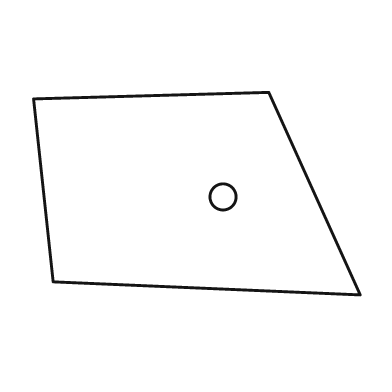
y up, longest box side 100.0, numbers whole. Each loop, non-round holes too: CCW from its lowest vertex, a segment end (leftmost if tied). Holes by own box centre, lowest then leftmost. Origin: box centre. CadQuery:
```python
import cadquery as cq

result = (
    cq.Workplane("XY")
    .moveTo(50.0, -31.0)
    .lineTo(22.0, 31.0)
    .lineTo(-50.0, 29.0)
    .lineTo(-44.0, -27.0)
    .close()
    .moveTo(8.0, -1.0)
    .circle(4.0)
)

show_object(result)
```